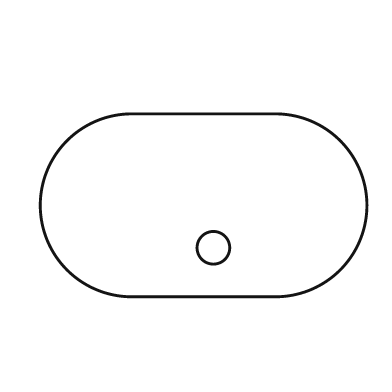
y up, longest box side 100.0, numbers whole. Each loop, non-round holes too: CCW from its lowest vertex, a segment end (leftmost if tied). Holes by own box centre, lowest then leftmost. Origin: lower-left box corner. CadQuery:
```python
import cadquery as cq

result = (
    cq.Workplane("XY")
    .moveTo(28.0, 0.0)
    .lineTo(72.0, 0.0)
    .threePointArc((100.0, 28.0), (72.0, 56.0))
    .lineTo(28.0, 56.0)
    .threePointArc((0.0, 28.0), (28.0, 0.0))
    .close()
    .moveTo(53.0, 15.0)
    .circle(5.0)
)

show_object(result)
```